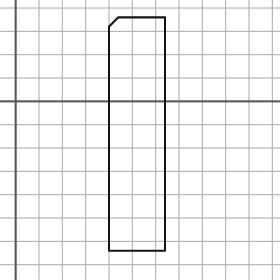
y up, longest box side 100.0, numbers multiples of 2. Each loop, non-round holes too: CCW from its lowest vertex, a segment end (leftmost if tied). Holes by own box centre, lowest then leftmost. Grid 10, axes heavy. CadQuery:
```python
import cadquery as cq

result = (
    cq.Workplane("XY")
    .moveTo(40.0, -64.0)
    .lineTo(64.0, -64.0)
    .lineTo(64.0, 36.0)
    .lineTo(44.0, 36.0)
    .lineTo(40.0, 32.0)
    .close()
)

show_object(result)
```